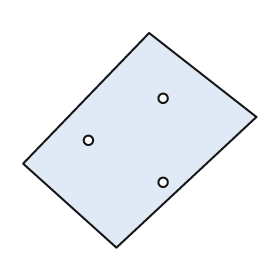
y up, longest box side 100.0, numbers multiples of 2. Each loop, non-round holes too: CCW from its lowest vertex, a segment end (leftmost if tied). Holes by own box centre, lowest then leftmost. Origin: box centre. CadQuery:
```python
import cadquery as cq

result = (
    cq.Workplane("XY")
    .moveTo(-10.0, -46.0)
    .lineTo(50.0, 10.0)
    .lineTo(4.0, 46.0)
    .lineTo(-50.0, -10.0)
    .close()
    .moveTo(10.0, -18.0)
    .circle(2.0)
    .moveTo(-22.0, 0.0)
    .circle(2.0)
    .moveTo(10.0, 18.0)
    .circle(2.0)
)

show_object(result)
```